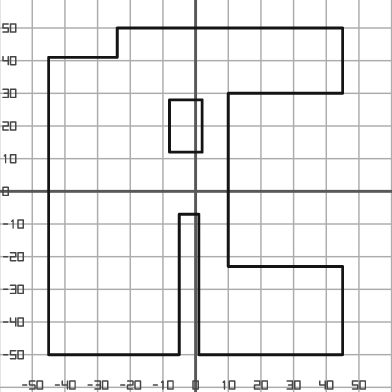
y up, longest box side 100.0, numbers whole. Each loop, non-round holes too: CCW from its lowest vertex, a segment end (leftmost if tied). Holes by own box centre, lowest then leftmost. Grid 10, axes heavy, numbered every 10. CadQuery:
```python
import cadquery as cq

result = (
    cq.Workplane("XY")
    .moveTo(-45.0, -50.0)
    .lineTo(-5.0, -50.0)
    .lineTo(-5.0, -7.0)
    .lineTo(1.0, -7.0)
    .lineTo(1.0, -50.0)
    .lineTo(45.0, -50.0)
    .lineTo(45.0, -23.0)
    .lineTo(10.0, -23.0)
    .lineTo(10.0, 30.0)
    .lineTo(45.0, 30.0)
    .lineTo(45.0, 50.0)
    .lineTo(-24.0, 50.0)
    .lineTo(-24.0, 41.0)
    .lineTo(-45.0, 41.0)
    .close()
    .moveTo(-8.0, 12.0)
    .lineTo(2.0, 12.0)
    .lineTo(2.0, 28.0)
    .lineTo(-8.0, 28.0)
    .close()
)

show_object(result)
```